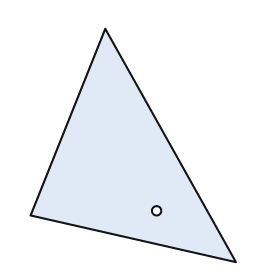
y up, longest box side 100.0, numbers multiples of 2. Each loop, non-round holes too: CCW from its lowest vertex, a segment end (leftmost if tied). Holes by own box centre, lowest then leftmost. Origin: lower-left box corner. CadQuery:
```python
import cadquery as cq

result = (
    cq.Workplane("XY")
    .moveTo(88.0, 0.0)
    .lineTo(32.0, 100.0)
    .lineTo(0.0, 20.0)
    .close()
    .moveTo(54.0, 22.0)
    .circle(2.0)
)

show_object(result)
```